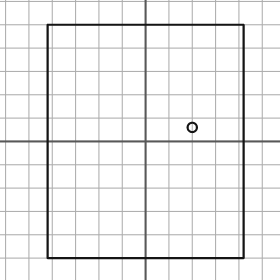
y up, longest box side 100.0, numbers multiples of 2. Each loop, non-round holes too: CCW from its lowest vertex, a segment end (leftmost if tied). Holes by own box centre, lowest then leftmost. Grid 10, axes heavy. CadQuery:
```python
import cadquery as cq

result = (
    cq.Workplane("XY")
    .moveTo(-42.0, -50.0)
    .lineTo(42.0, -50.0)
    .lineTo(42.0, 50.0)
    .lineTo(-42.0, 50.0)
    .close()
    .moveTo(20.0, 6.0)
    .circle(2.0)
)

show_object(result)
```